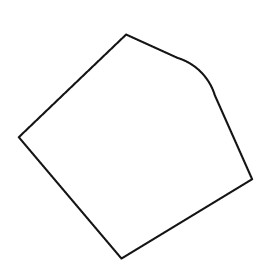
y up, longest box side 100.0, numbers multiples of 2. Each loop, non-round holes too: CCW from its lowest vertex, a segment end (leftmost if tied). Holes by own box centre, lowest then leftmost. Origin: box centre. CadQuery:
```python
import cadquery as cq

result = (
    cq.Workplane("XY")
    .moveTo(-6.0, -48.0)
    .lineTo(50.0, -14.0)
    .lineTo(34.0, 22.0)
    .threePointArc((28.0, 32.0), (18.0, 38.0))
    .lineTo(-4.0, 48.0)
    .lineTo(-50.0, 4.0)
    .close()
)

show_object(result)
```